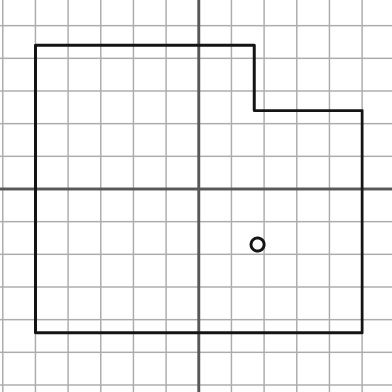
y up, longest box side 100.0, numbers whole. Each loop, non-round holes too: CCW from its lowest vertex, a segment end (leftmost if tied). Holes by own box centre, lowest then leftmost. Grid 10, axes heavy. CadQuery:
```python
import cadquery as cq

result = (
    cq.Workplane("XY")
    .moveTo(-50.0, -44.0)
    .lineTo(50.0, -44.0)
    .lineTo(50.0, 24.0)
    .lineTo(17.0, 24.0)
    .lineTo(17.0, 44.0)
    .lineTo(-50.0, 44.0)
    .close()
    .moveTo(18.0, -17.0)
    .circle(2.0)
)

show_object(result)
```